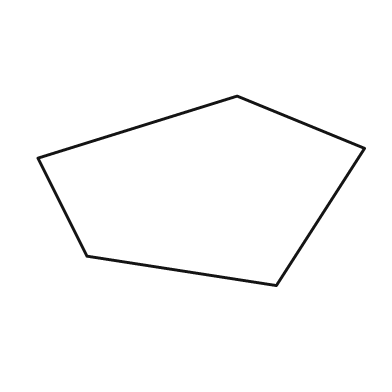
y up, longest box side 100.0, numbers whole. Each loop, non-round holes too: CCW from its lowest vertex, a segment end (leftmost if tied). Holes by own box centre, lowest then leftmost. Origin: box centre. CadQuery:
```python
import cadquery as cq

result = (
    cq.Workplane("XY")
    .moveTo(23.0, -29.0)
    .lineTo(50.0, 13.0)
    .lineTo(11.0, 29.0)
    .lineTo(-50.0, 10.0)
    .lineTo(-35.0, -20.0)
    .close()
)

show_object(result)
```